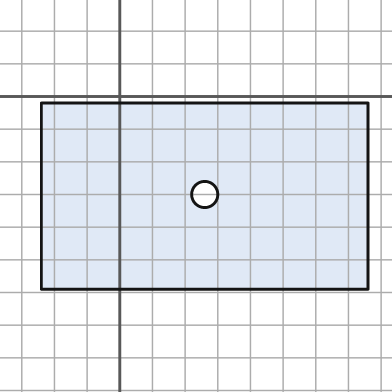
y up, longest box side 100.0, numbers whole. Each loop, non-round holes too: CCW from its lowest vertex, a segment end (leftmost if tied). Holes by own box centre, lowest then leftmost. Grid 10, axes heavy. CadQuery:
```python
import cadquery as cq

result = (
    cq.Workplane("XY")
    .moveTo(-24.0, -59.0)
    .lineTo(76.0, -59.0)
    .lineTo(76.0, -2.0)
    .lineTo(-24.0, -2.0)
    .close()
    .moveTo(26.0, -30.0)
    .circle(4.0)
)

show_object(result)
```